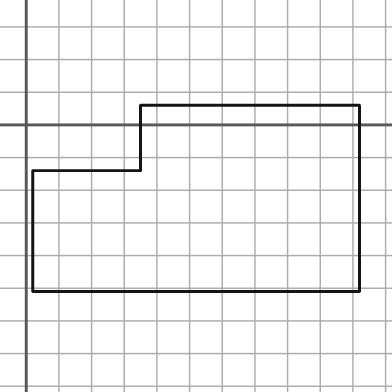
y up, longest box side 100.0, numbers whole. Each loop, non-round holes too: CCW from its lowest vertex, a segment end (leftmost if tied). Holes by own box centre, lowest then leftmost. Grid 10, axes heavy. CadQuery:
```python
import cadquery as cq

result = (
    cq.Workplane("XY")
    .moveTo(2.0, -51.0)
    .lineTo(102.0, -51.0)
    .lineTo(102.0, 6.0)
    .lineTo(35.0, 6.0)
    .lineTo(35.0, -14.0)
    .lineTo(2.0, -14.0)
    .close()
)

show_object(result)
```